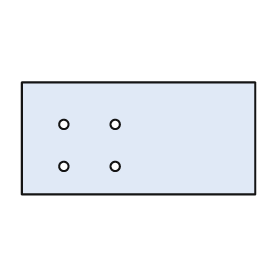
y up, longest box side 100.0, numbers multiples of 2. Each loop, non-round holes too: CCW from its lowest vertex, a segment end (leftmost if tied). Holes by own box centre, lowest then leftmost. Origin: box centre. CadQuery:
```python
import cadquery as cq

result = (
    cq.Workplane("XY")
    .moveTo(-50.0, -24.0)
    .lineTo(50.0, -24.0)
    .lineTo(50.0, 24.0)
    .lineTo(-50.0, 24.0)
    .close()
    .moveTo(-32.0, -12.0)
    .circle(2.0)
    .moveTo(-10.0, -12.0)
    .circle(2.0)
    .moveTo(-32.0, 6.0)
    .circle(2.0)
    .moveTo(-10.0, 6.0)
    .circle(2.0)
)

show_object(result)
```